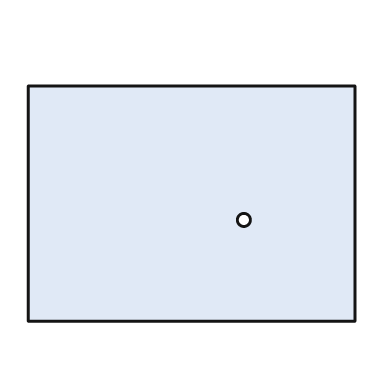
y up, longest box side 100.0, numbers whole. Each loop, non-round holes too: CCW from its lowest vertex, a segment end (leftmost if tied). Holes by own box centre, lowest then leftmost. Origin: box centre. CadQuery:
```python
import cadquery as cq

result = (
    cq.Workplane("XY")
    .moveTo(-50.0, -36.0)
    .lineTo(50.0, -36.0)
    .lineTo(50.0, 36.0)
    .lineTo(-50.0, 36.0)
    .close()
    .moveTo(16.0, -5.0)
    .circle(2.0)
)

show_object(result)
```